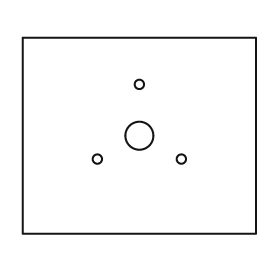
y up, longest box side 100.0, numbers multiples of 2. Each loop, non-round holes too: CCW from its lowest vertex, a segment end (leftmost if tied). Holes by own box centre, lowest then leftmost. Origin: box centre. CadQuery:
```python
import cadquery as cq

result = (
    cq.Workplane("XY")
    .moveTo(-50.0, -42.0)
    .lineTo(50.0, -42.0)
    .lineTo(50.0, 42.0)
    .lineTo(-50.0, 42.0)
    .close()
    .moveTo(-18.0, -10.0)
    .circle(2.0)
    .moveTo(18.0, -10.0)
    .circle(2.0)
    .moveTo(0.0, 0.0)
    .circle(6.0)
    .moveTo(0.0, 22.0)
    .circle(2.0)
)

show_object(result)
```